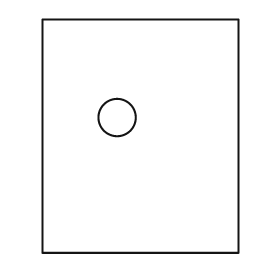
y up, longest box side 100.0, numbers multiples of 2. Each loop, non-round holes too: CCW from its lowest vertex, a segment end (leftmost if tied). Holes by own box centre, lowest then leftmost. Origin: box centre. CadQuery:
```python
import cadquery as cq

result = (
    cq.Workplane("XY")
    .moveTo(-42.0, -50.0)
    .lineTo(42.0, -50.0)
    .lineTo(42.0, 50.0)
    .lineTo(-42.0, 50.0)
    .close()
    .moveTo(-10.0, 8.0)
    .circle(8.0)
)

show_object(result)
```